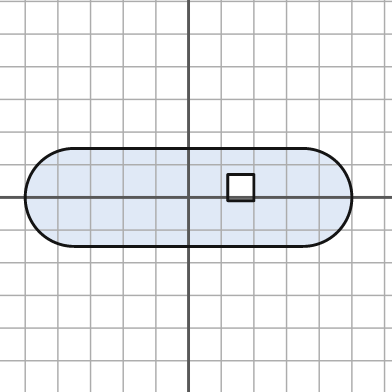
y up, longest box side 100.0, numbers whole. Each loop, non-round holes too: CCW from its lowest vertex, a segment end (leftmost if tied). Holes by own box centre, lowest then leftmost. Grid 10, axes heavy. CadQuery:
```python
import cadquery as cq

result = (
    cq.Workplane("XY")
    .moveTo(-35.0, -15.0)
    .lineTo(35.0, -15.0)
    .threePointArc((50.0, 0.0), (35.0, 15.0))
    .lineTo(-35.0, 15.0)
    .threePointArc((-50.0, 0.0), (-35.0, -15.0))
    .close()
    .moveTo(12.0, -1.0)
    .lineTo(20.0, -1.0)
    .lineTo(20.0, 7.0)
    .lineTo(12.0, 7.0)
    .close()
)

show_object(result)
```